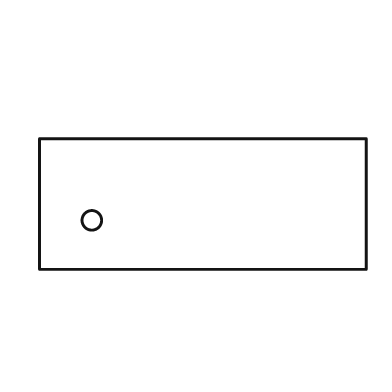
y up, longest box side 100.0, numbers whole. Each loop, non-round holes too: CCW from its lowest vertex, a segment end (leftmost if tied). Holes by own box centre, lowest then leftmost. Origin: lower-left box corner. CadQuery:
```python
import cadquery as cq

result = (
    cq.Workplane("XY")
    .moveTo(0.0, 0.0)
    .lineTo(100.0, 0.0)
    .lineTo(100.0, 40.0)
    .lineTo(0.0, 40.0)
    .close()
    .moveTo(16.0, 15.0)
    .circle(3.0)
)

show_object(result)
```